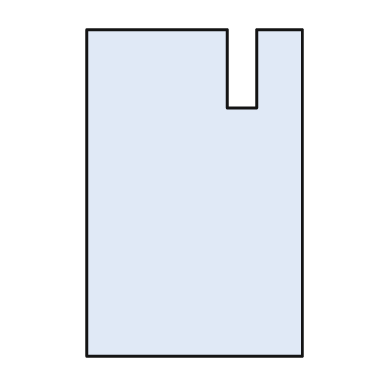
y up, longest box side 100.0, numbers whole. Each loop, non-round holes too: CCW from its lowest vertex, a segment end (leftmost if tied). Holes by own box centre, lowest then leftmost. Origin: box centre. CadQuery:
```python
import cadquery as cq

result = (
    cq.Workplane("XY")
    .moveTo(-33.0, -50.0)
    .lineTo(33.0, -50.0)
    .lineTo(33.0, 50.0)
    .lineTo(19.0, 50.0)
    .lineTo(19.0, 26.0)
    .lineTo(10.0, 26.0)
    .lineTo(10.0, 50.0)
    .lineTo(-33.0, 50.0)
    .close()
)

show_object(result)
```